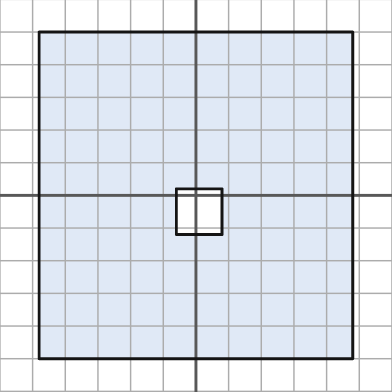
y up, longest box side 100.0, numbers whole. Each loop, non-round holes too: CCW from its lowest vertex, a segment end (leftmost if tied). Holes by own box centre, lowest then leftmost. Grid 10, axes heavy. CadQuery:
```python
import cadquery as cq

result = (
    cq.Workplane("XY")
    .moveTo(-48.0, -50.0)
    .lineTo(48.0, -50.0)
    .lineTo(48.0, 50.0)
    .lineTo(-48.0, 50.0)
    .close()
    .moveTo(-6.0, -12.0)
    .lineTo(8.0, -12.0)
    .lineTo(8.0, 2.0)
    .lineTo(-6.0, 2.0)
    .close()
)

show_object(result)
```